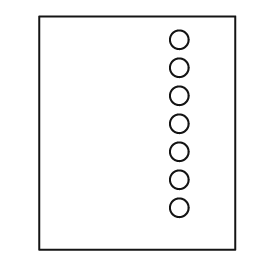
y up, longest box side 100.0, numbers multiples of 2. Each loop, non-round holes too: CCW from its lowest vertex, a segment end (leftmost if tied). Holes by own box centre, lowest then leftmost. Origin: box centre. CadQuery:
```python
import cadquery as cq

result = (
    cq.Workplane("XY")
    .moveTo(-42.0, -50.0)
    .lineTo(42.0, -50.0)
    .lineTo(42.0, 50.0)
    .lineTo(-42.0, 50.0)
    .close()
    .moveTo(18.0, -32.0)
    .circle(4.0)
    .moveTo(18.0, -20.0)
    .circle(4.0)
    .moveTo(18.0, -8.0)
    .circle(4.0)
    .moveTo(18.0, 4.0)
    .circle(4.0)
    .moveTo(18.0, 16.0)
    .circle(4.0)
    .moveTo(18.0, 28.0)
    .circle(4.0)
    .moveTo(18.0, 40.0)
    .circle(4.0)
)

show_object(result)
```